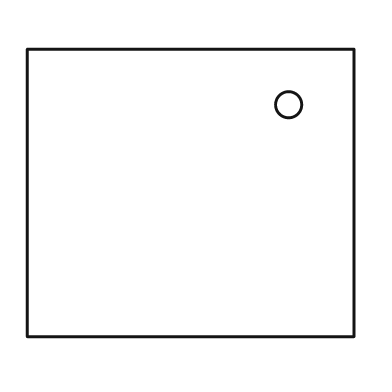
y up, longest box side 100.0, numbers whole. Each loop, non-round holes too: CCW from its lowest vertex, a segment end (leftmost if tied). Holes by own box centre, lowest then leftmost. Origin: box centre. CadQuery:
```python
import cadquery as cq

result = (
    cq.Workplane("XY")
    .moveTo(-50.0, -44.0)
    .lineTo(50.0, -44.0)
    .lineTo(50.0, 44.0)
    .lineTo(-50.0, 44.0)
    .close()
    .moveTo(30.0, 27.0)
    .circle(4.0)
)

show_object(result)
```